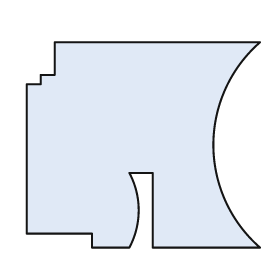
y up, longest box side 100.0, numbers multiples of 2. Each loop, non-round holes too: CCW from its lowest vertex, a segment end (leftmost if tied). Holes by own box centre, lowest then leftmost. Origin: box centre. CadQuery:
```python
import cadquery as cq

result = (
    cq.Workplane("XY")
    .moveTo(-22.0, -44.0)
    .lineTo(-6.0, -44.0)
    .threePointArc((-2.0, -28.0), (-6.0, -12.0))
    .lineTo(4.0, -12.0)
    .lineTo(4.0, -44.0)
    .lineTo(50.0, -44.0)
    .threePointArc((30.0, 0.0), (50.0, 44.0))
    .lineTo(-38.0, 44.0)
    .lineTo(-38.0, 30.0)
    .lineTo(-44.0, 30.0)
    .lineTo(-44.0, 26.0)
    .lineTo(-50.0, 26.0)
    .lineTo(-50.0, -38.0)
    .lineTo(-22.0, -38.0)
    .close()
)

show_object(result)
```